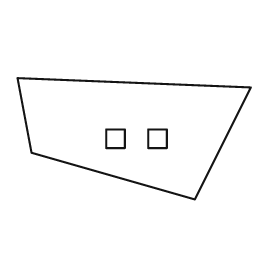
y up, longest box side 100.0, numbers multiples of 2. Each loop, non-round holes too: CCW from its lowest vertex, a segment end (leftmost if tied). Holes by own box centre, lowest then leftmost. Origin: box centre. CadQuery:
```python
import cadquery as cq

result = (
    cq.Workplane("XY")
    .moveTo(26.0, -26.0)
    .lineTo(50.0, 22.0)
    .lineTo(-50.0, 26.0)
    .lineTo(-44.0, -6.0)
    .close()
    .moveTo(-12.0, -4.0)
    .lineTo(-4.0, -4.0)
    .lineTo(-4.0, 4.0)
    .lineTo(-12.0, 4.0)
    .close()
    .moveTo(6.0, -4.0)
    .lineTo(14.0, -4.0)
    .lineTo(14.0, 4.0)
    .lineTo(6.0, 4.0)
    .close()
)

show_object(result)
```